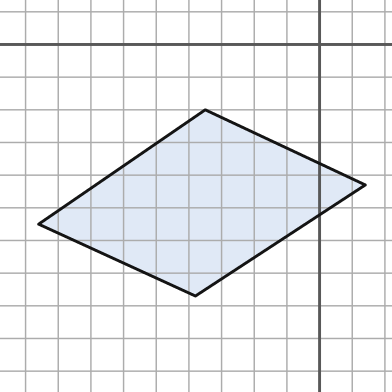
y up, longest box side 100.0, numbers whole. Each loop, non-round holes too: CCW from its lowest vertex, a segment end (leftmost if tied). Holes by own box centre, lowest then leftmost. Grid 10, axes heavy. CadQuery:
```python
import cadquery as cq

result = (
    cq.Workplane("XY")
    .moveTo(-38.0, -77.0)
    .lineTo(14.0, -43.0)
    .lineTo(-35.0, -20.0)
    .lineTo(-86.0, -55.0)
    .close()
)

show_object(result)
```